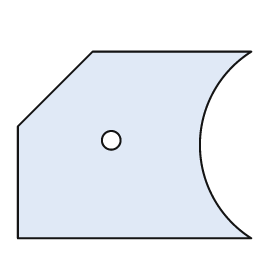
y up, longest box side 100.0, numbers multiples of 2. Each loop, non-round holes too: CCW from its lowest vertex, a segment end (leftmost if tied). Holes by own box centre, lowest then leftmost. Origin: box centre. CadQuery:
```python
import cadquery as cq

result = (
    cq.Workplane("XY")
    .moveTo(-50.0, -40.0)
    .lineTo(50.0, -40.0)
    .threePointArc((28.0, 0.0), (50.0, 40.0))
    .lineTo(-18.0, 40.0)
    .lineTo(-50.0, 8.0)
    .close()
    .moveTo(-10.0, 2.0)
    .circle(4.0)
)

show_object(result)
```